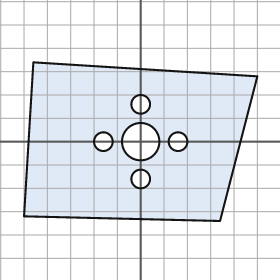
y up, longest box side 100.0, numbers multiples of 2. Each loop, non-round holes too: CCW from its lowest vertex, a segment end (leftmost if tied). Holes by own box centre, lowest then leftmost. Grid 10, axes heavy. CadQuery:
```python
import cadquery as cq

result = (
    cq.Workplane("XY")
    .moveTo(34.0, -34.0)
    .lineTo(50.0, 28.0)
    .lineTo(-46.0, 34.0)
    .lineTo(-50.0, -32.0)
    .close()
    .moveTo(0.0, -16.0)
    .circle(4.0)
    .moveTo(-16.0, 0.0)
    .circle(4.0)
    .moveTo(0.0, 0.0)
    .circle(8.0)
    .moveTo(16.0, 0.0)
    .circle(4.0)
    .moveTo(0.0, 16.0)
    .circle(4.0)
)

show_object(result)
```